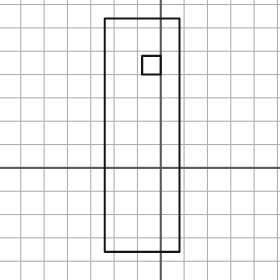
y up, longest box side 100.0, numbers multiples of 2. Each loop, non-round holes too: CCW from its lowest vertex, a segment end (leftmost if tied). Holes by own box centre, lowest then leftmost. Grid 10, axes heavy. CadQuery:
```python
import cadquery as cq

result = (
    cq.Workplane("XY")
    .moveTo(-24.0, -36.0)
    .lineTo(8.0, -36.0)
    .lineTo(8.0, 64.0)
    .lineTo(-24.0, 64.0)
    .close()
    .moveTo(-8.0, 40.0)
    .lineTo(0.0, 40.0)
    .lineTo(0.0, 48.0)
    .lineTo(-8.0, 48.0)
    .close()
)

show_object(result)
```